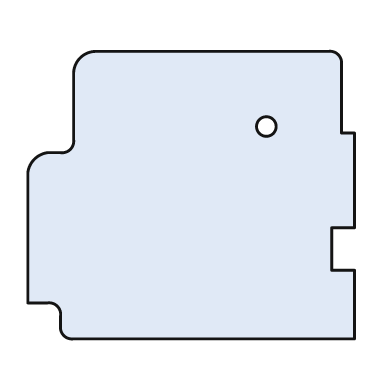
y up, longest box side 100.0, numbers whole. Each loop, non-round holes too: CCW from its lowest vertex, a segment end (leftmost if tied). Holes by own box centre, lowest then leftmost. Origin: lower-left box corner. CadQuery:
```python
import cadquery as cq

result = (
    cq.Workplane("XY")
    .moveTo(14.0, 0.0)
    .lineTo(100.0, 0.0)
    .lineTo(100.0, 21.0)
    .lineTo(93.0, 21.0)
    .lineTo(93.0, 34.0)
    .lineTo(100.0, 34.0)
    .lineTo(100.0, 63.0)
    .lineTo(96.0, 63.0)
    .lineTo(96.0, 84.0)
    .threePointArc((95.0, 87.0), (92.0, 88.0))
    .lineTo(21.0, 88.0)
    .threePointArc((16.0, 86.0), (14.0, 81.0))
    .lineTo(14.0, 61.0)
    .threePointArc((13.0, 58.0), (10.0, 57.0))
    .lineTo(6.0, 57.0)
    .threePointArc((2.0, 55.0), (0.0, 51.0))
    .lineTo(0.0, 11.0)
    .lineTo(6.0, 11.0)
    .threePointArc((9.0, 10.0), (10.0, 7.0))
    .lineTo(10.0, 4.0)
    .threePointArc((11.0, 1.0), (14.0, 0.0))
    .close()
    .moveTo(73.0, 65.0)
    .circle(3.0)
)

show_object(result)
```